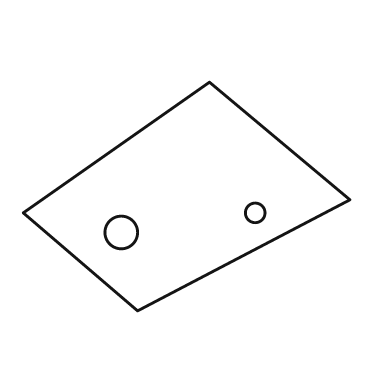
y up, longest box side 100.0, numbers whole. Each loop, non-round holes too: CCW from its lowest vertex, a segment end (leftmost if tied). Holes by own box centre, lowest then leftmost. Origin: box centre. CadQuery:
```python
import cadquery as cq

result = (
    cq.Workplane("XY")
    .moveTo(-15.0, -35.0)
    .lineTo(50.0, -1.0)
    .lineTo(7.0, 35.0)
    .lineTo(-50.0, -5.0)
    .close()
    .moveTo(-20.0, -11.0)
    .circle(5.0)
    .moveTo(21.0, -5.0)
    .circle(3.0)
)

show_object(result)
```